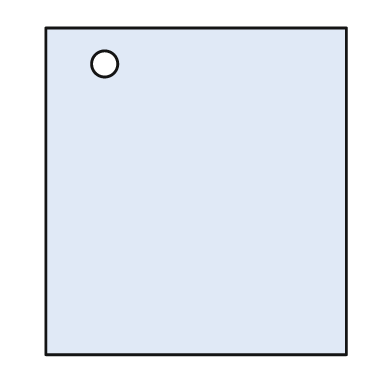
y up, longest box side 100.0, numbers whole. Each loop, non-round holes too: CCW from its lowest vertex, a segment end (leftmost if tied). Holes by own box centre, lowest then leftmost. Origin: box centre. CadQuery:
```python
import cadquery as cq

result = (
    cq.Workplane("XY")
    .moveTo(-46.0, -50.0)
    .lineTo(46.0, -50.0)
    .lineTo(46.0, 50.0)
    .lineTo(-46.0, 50.0)
    .close()
    .moveTo(-28.0, 39.0)
    .circle(4.0)
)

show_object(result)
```